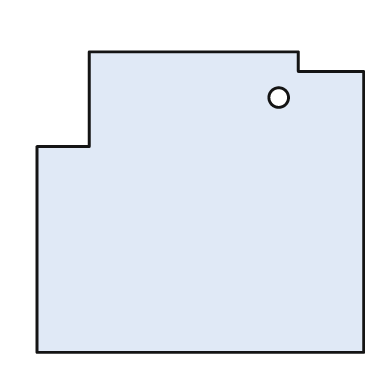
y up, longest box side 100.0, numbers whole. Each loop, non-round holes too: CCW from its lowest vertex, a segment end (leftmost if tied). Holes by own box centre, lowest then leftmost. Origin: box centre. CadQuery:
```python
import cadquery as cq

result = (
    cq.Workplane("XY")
    .moveTo(-50.0, -46.0)
    .lineTo(50.0, -46.0)
    .lineTo(50.0, 40.0)
    .lineTo(30.0, 40.0)
    .lineTo(30.0, 46.0)
    .lineTo(-34.0, 46.0)
    .lineTo(-34.0, 17.0)
    .lineTo(-50.0, 17.0)
    .close()
    .moveTo(24.0, 32.0)
    .circle(3.0)
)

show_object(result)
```